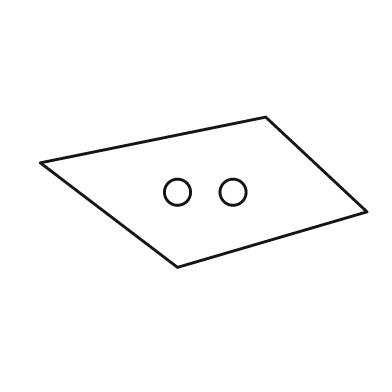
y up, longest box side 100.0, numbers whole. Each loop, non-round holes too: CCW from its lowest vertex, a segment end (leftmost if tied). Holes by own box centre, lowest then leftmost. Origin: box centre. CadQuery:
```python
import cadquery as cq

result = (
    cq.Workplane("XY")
    .moveTo(-8.0, -23.0)
    .lineTo(50.0, -6.0)
    .lineTo(19.0, 23.0)
    .lineTo(-50.0, 9.0)
    .close()
    .moveTo(-8.0, 0.0)
    .circle(4.0)
    .moveTo(9.0, 0.0)
    .circle(4.0)
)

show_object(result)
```